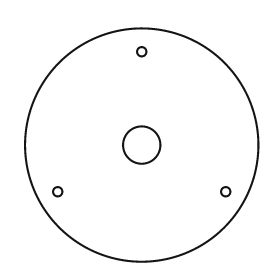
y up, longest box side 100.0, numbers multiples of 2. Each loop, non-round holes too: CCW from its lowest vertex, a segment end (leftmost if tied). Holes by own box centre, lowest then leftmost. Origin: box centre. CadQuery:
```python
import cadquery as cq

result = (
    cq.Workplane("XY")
    .moveTo(0.0, 0.0)
    .circle(50.0)
    .moveTo(-36.0, -20.0)
    .circle(2.0)
    .moveTo(36.0, -20.0)
    .circle(2.0)
    .moveTo(0.0, 0.0)
    .circle(8.0)
    .moveTo(0.0, 40.0)
    .circle(2.0)
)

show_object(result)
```